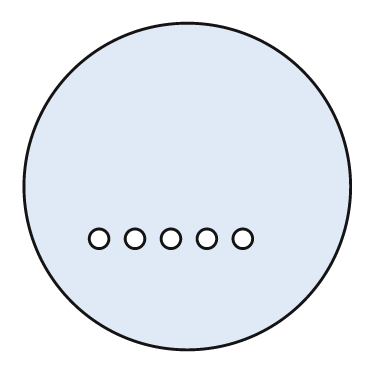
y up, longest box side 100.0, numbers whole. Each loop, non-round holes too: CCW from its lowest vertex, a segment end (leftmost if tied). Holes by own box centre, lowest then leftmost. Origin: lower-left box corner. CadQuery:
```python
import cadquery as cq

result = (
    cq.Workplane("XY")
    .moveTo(50.0, 50.0)
    .circle(50.0)
    .moveTo(23.0, 34.0)
    .circle(3.0)
    .moveTo(34.0, 34.0)
    .circle(3.0)
    .moveTo(45.0, 34.0)
    .circle(3.0)
    .moveTo(56.0, 34.0)
    .circle(3.0)
    .moveTo(67.0, 34.0)
    .circle(3.0)
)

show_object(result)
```